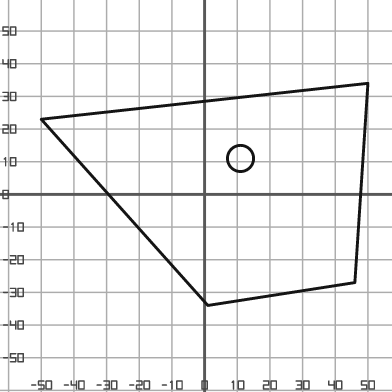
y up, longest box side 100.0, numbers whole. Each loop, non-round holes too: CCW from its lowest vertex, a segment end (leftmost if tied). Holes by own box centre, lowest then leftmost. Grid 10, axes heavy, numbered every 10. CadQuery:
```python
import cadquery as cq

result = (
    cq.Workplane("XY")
    .moveTo(1.0, -34.0)
    .lineTo(46.0, -27.0)
    .lineTo(50.0, 34.0)
    .lineTo(-50.0, 23.0)
    .close()
    .moveTo(11.0, 11.0)
    .circle(4.0)
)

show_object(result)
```